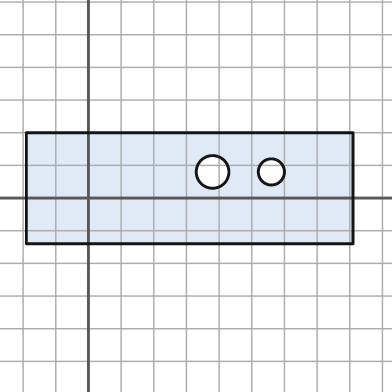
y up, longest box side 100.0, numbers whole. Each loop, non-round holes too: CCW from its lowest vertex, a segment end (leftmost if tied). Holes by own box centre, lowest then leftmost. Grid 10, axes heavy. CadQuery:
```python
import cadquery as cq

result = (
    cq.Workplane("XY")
    .moveTo(-19.0, -14.0)
    .lineTo(81.0, -14.0)
    .lineTo(81.0, 20.0)
    .lineTo(-19.0, 20.0)
    .close()
    .moveTo(38.0, 8.0)
    .circle(5.0)
    .moveTo(56.0, 8.0)
    .circle(4.0)
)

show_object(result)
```